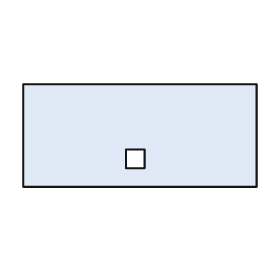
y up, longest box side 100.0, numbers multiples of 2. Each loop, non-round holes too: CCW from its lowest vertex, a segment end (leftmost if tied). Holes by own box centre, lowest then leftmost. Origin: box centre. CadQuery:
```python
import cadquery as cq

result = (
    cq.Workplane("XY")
    .moveTo(-50.0, -22.0)
    .lineTo(50.0, -22.0)
    .lineTo(50.0, 22.0)
    .lineTo(-50.0, 22.0)
    .close()
    .moveTo(-6.0, -14.0)
    .lineTo(2.0, -14.0)
    .lineTo(2.0, -6.0)
    .lineTo(-6.0, -6.0)
    .close()
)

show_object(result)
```